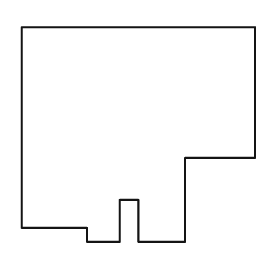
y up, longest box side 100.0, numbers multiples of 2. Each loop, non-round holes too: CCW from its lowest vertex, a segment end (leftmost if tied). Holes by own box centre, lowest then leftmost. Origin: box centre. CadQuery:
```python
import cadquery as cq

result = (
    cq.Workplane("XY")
    .moveTo(-22.0, -46.0)
    .lineTo(-8.0, -46.0)
    .lineTo(-8.0, -28.0)
    .lineTo(0.0, -28.0)
    .lineTo(0.0, -46.0)
    .lineTo(20.0, -46.0)
    .lineTo(20.0, -10.0)
    .lineTo(50.0, -10.0)
    .lineTo(50.0, 46.0)
    .lineTo(-50.0, 46.0)
    .lineTo(-50.0, -40.0)
    .lineTo(-22.0, -40.0)
    .close()
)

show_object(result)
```